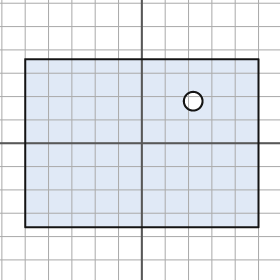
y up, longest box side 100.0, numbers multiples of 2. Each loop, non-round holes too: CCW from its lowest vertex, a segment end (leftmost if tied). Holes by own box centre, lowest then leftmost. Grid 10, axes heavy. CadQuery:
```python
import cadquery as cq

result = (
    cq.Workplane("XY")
    .moveTo(-50.0, -36.0)
    .lineTo(50.0, -36.0)
    .lineTo(50.0, 36.0)
    .lineTo(-50.0, 36.0)
    .close()
    .moveTo(22.0, 18.0)
    .circle(4.0)
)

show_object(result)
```